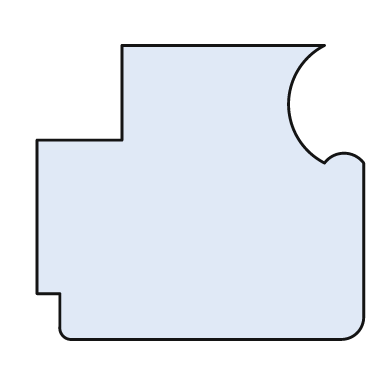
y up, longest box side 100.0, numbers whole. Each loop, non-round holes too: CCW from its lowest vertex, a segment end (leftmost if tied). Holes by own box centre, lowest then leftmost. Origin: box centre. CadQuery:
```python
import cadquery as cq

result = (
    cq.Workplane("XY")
    .moveTo(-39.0, -45.0)
    .lineTo(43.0, -45.0)
    .threePointArc((48.0, -43.0), (50.0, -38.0))
    .lineTo(50.0, 9.0)
    .threePointArc((44.0, 12.0), (38.0, 9.0))
    .threePointArc((27.0, 27.0), (38.0, 45.0))
    .lineTo(-24.0, 45.0)
    .lineTo(-24.0, 16.0)
    .lineTo(-50.0, 16.0)
    .lineTo(-50.0, -31.0)
    .lineTo(-43.0, -31.0)
    .lineTo(-43.0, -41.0)
    .threePointArc((-42.0, -44.0), (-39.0, -45.0))
    .close()
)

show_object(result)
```